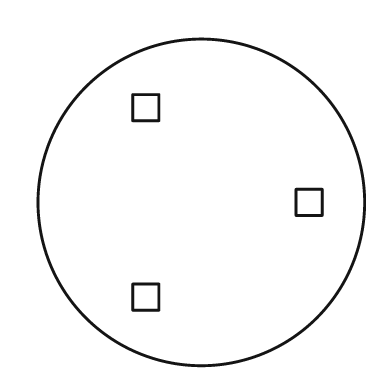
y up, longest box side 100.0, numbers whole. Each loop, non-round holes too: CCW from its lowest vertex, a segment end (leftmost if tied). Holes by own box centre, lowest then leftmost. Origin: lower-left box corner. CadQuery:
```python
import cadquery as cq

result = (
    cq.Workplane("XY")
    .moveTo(50.0, 50.0)
    .circle(50.0)
    .moveTo(29.0, 17.0)
    .lineTo(37.0, 17.0)
    .lineTo(37.0, 25.0)
    .lineTo(29.0, 25.0)
    .close()
    .moveTo(79.0, 46.0)
    .lineTo(87.0, 46.0)
    .lineTo(87.0, 54.0)
    .lineTo(79.0, 54.0)
    .close()
    .moveTo(29.0, 75.0)
    .lineTo(37.0, 75.0)
    .lineTo(37.0, 83.0)
    .lineTo(29.0, 83.0)
    .close()
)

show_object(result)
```